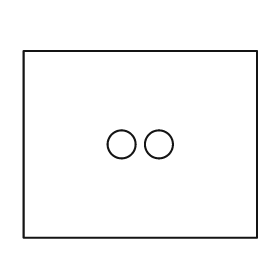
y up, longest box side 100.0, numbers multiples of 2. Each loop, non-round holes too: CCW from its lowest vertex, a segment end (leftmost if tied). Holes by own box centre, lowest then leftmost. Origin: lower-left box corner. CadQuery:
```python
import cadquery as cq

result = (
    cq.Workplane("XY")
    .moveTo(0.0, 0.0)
    .lineTo(100.0, 0.0)
    .lineTo(100.0, 80.0)
    .lineTo(0.0, 80.0)
    .close()
    .moveTo(42.0, 40.0)
    .circle(6.0)
    .moveTo(58.0, 40.0)
    .circle(6.0)
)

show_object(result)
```